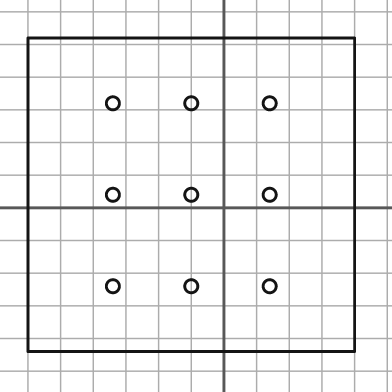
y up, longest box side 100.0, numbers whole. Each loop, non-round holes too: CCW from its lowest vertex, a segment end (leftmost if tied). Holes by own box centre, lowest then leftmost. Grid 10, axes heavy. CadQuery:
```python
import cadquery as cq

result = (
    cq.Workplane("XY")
    .moveTo(-60.0, -44.0)
    .lineTo(40.0, -44.0)
    .lineTo(40.0, 52.0)
    .lineTo(-60.0, 52.0)
    .close()
    .moveTo(-34.0, -24.0)
    .circle(2.0)
    .moveTo(-10.0, -24.0)
    .circle(2.0)
    .moveTo(14.0, -24.0)
    .circle(2.0)
    .moveTo(-34.0, 4.0)
    .circle(2.0)
    .moveTo(-10.0, 4.0)
    .circle(2.0)
    .moveTo(14.0, 4.0)
    .circle(2.0)
    .moveTo(-34.0, 32.0)
    .circle(2.0)
    .moveTo(-10.0, 32.0)
    .circle(2.0)
    .moveTo(14.0, 32.0)
    .circle(2.0)
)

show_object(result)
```